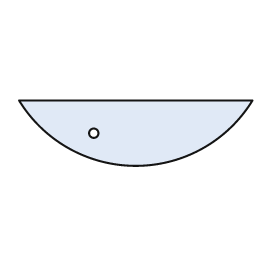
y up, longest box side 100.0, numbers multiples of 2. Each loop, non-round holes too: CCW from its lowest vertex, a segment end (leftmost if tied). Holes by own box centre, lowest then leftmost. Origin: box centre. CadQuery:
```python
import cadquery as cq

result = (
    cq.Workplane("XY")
    .moveTo(-50.0, 14.0)
    .threePointArc((0.0, -14.0), (50.0, 14.0))
    .close()
    .moveTo(-18.0, 0.0)
    .circle(2.0)
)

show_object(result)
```